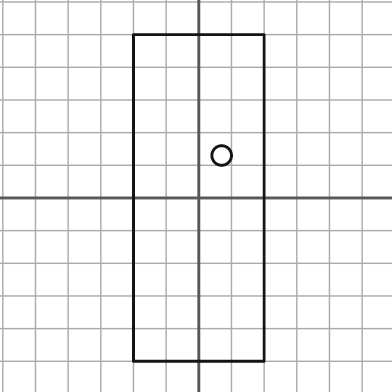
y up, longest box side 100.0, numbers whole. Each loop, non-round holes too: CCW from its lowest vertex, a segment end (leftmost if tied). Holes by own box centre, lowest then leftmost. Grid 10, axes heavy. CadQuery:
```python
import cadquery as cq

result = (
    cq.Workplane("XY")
    .moveTo(-20.0, -50.0)
    .lineTo(20.0, -50.0)
    .lineTo(20.0, 50.0)
    .lineTo(-20.0, 50.0)
    .close()
    .moveTo(7.0, 13.0)
    .circle(3.0)
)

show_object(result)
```